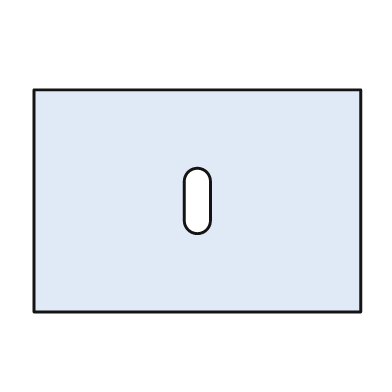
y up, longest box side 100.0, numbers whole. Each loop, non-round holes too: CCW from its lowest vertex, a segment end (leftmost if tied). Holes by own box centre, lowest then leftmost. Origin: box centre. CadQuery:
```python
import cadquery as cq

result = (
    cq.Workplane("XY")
    .moveTo(-50.0, -34.0)
    .lineTo(50.0, -34.0)
    .lineTo(50.0, 34.0)
    .lineTo(-50.0, 34.0)
    .close()
    .moveTo(-4.0, -6.0)
    .threePointArc((0.0, -10.0), (4.0, -6.0))
    .lineTo(4.0, 6.0)
    .threePointArc((0.0, 10.0), (-4.0, 6.0))
    .close()
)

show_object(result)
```